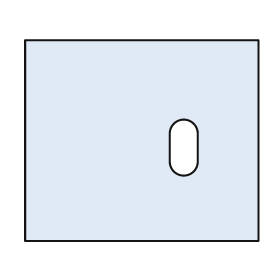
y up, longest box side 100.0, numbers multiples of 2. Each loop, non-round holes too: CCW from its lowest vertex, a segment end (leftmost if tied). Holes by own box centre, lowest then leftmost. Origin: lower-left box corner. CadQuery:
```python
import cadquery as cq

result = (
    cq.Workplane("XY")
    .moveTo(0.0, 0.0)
    .lineTo(100.0, 0.0)
    .lineTo(100.0, 86.0)
    .lineTo(0.0, 86.0)
    .close()
    .moveTo(62.0, 34.0)
    .threePointArc((68.0, 28.0), (74.0, 34.0))
    .lineTo(74.0, 46.0)
    .threePointArc((68.0, 52.0), (62.0, 46.0))
    .close()
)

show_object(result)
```